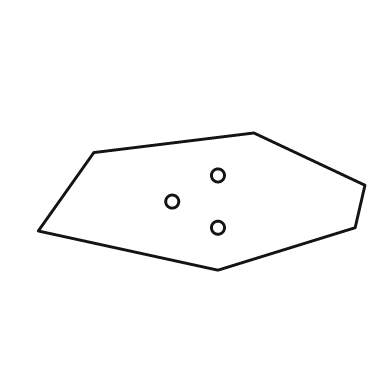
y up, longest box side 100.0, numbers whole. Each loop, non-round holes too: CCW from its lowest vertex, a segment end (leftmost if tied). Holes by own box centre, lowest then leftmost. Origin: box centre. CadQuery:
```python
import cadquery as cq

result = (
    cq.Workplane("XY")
    .moveTo(5.0, -21.0)
    .lineTo(47.0, -8.0)
    .lineTo(50.0, 5.0)
    .lineTo(16.0, 21.0)
    .lineTo(-33.0, 15.0)
    .lineTo(-50.0, -9.0)
    .close()
    .moveTo(5.0, -8.0)
    .circle(2.0)
    .moveTo(-9.0, 0.0)
    .circle(2.0)
    .moveTo(5.0, 8.0)
    .circle(2.0)
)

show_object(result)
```